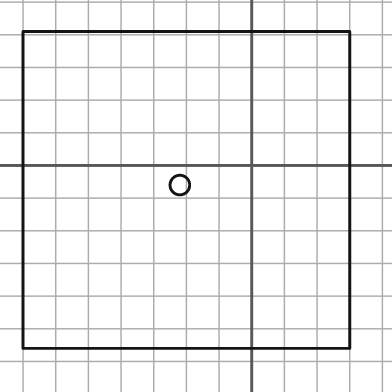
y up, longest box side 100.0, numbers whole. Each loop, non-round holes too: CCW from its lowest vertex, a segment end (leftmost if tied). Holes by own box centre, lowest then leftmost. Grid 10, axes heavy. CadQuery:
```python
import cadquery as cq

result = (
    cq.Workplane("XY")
    .moveTo(-70.0, -56.0)
    .lineTo(30.0, -56.0)
    .lineTo(30.0, 41.0)
    .lineTo(-70.0, 41.0)
    .close()
    .moveTo(-22.0, -6.0)
    .circle(3.0)
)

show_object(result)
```